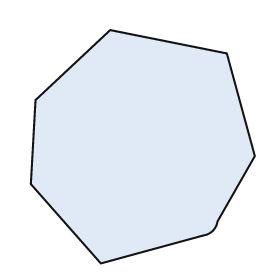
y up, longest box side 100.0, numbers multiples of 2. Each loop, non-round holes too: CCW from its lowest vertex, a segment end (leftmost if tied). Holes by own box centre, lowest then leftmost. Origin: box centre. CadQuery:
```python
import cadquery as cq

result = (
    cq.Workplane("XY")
    .moveTo(-18.0, -50.0)
    .lineTo(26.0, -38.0)
    .threePointArc((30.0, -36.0), (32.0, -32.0))
    .lineTo(48.0, -4.0)
    .lineTo(36.0, 40.0)
    .lineTo(-14.0, 50.0)
    .lineTo(-46.0, 20.0)
    .lineTo(-48.0, -16.0)
    .close()
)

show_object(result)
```